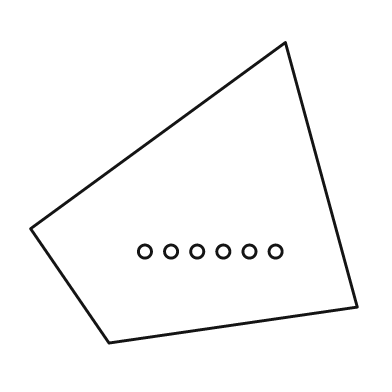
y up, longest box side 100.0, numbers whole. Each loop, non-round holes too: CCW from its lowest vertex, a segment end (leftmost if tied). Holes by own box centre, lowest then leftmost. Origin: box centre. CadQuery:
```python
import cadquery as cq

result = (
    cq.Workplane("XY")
    .moveTo(-26.0, -46.0)
    .lineTo(50.0, -35.0)
    .lineTo(28.0, 46.0)
    .lineTo(-50.0, -11.0)
    .close()
    .moveTo(-15.0, -18.0)
    .circle(2.0)
    .moveTo(-7.0, -18.0)
    .circle(2.0)
    .moveTo(1.0, -18.0)
    .circle(2.0)
    .moveTo(9.0, -18.0)
    .circle(2.0)
    .moveTo(17.0, -18.0)
    .circle(2.0)
    .moveTo(25.0, -18.0)
    .circle(2.0)
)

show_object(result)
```